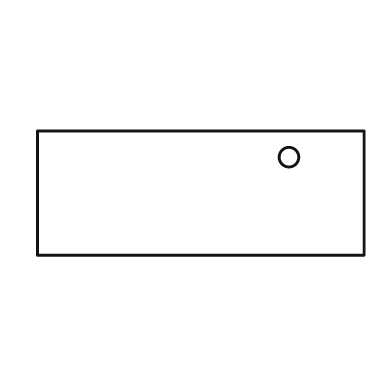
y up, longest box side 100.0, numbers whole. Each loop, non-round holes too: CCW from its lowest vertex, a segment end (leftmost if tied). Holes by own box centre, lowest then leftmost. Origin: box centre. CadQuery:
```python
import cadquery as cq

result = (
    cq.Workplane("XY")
    .moveTo(-50.0, -19.0)
    .lineTo(50.0, -19.0)
    .lineTo(50.0, 19.0)
    .lineTo(-50.0, 19.0)
    .close()
    .moveTo(27.0, 11.0)
    .circle(3.0)
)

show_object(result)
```